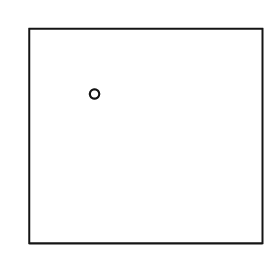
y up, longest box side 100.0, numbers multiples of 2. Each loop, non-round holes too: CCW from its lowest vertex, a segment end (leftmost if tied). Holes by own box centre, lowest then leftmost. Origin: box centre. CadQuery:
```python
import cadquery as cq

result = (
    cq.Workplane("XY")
    .moveTo(-50.0, -46.0)
    .lineTo(50.0, -46.0)
    .lineTo(50.0, 46.0)
    .lineTo(-50.0, 46.0)
    .close()
    .moveTo(-22.0, 18.0)
    .circle(2.0)
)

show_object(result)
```